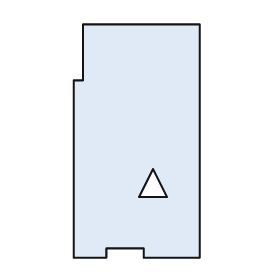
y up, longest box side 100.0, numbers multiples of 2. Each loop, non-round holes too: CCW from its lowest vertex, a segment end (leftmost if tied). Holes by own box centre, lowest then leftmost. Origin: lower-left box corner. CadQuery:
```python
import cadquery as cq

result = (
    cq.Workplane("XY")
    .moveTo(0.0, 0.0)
    .lineTo(14.0, 0.0)
    .lineTo(14.0, 4.0)
    .lineTo(30.0, 4.0)
    .lineTo(30.0, 0.0)
    .lineTo(54.0, 0.0)
    .lineTo(54.0, 100.0)
    .lineTo(4.0, 100.0)
    .lineTo(4.0, 76.0)
    .lineTo(0.0, 76.0)
    .close()
    .moveTo(28.0, 26.0)
    .lineTo(40.0, 26.0)
    .lineTo(34.0, 38.0)
    .close()
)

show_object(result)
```